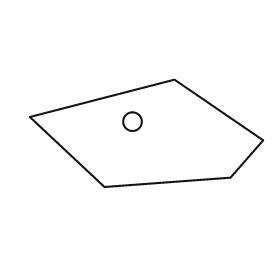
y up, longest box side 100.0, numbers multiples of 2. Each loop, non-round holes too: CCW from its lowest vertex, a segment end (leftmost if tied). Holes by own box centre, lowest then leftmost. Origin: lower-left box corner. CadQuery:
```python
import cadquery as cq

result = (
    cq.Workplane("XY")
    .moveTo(32.0, 0.0)
    .lineTo(86.0, 4.0)
    .lineTo(100.0, 20.0)
    .lineTo(62.0, 46.0)
    .lineTo(0.0, 30.0)
    .close()
    .moveTo(44.0, 28.0)
    .circle(4.0)
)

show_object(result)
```